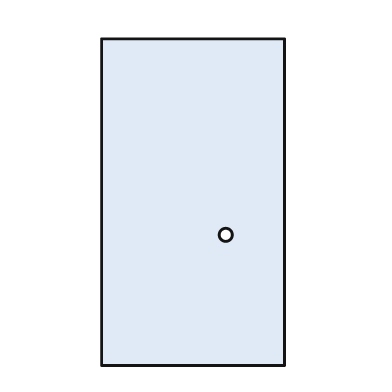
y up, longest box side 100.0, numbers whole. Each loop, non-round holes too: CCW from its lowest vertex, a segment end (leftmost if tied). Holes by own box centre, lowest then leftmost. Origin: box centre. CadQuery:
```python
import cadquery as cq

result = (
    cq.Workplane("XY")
    .moveTo(-28.0, -50.0)
    .lineTo(28.0, -50.0)
    .lineTo(28.0, 50.0)
    .lineTo(-28.0, 50.0)
    .close()
    .moveTo(10.0, -10.0)
    .circle(2.0)
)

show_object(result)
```